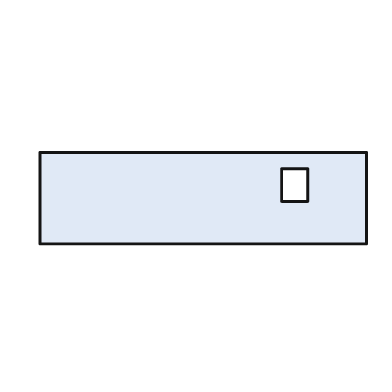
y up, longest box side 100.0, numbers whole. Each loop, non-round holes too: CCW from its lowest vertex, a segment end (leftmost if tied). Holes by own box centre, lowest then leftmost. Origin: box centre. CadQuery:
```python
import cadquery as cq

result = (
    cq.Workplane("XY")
    .moveTo(-50.0, -14.0)
    .lineTo(50.0, -14.0)
    .lineTo(50.0, 14.0)
    .lineTo(-50.0, 14.0)
    .close()
    .moveTo(24.0, -1.0)
    .lineTo(32.0, -1.0)
    .lineTo(32.0, 9.0)
    .lineTo(24.0, 9.0)
    .close()
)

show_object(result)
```